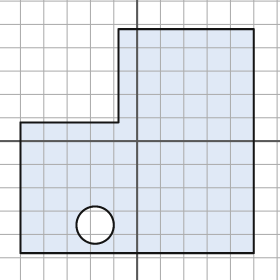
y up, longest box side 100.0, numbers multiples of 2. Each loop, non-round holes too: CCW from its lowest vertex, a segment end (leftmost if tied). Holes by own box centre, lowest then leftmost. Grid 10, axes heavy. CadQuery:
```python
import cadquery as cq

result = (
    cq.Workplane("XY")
    .moveTo(-50.0, -48.0)
    .lineTo(50.0, -48.0)
    .lineTo(50.0, 48.0)
    .lineTo(-8.0, 48.0)
    .lineTo(-8.0, 8.0)
    .lineTo(-50.0, 8.0)
    .close()
    .moveTo(-18.0, -36.0)
    .circle(8.0)
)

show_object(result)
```